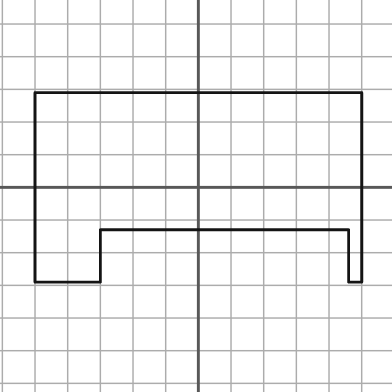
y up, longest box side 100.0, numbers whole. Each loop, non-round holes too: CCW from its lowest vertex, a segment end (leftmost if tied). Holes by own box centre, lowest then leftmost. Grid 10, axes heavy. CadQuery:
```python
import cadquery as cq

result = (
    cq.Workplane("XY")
    .moveTo(-50.0, -29.0)
    .lineTo(-30.0, -29.0)
    .lineTo(-30.0, -13.0)
    .lineTo(46.0, -13.0)
    .lineTo(46.0, -29.0)
    .lineTo(50.0, -29.0)
    .lineTo(50.0, 29.0)
    .lineTo(-50.0, 29.0)
    .close()
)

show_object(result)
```